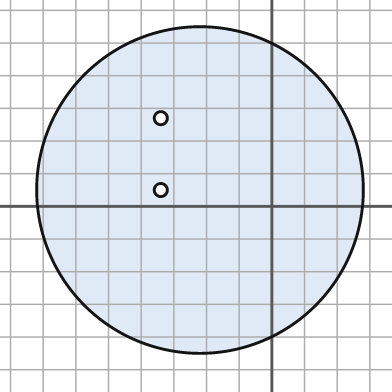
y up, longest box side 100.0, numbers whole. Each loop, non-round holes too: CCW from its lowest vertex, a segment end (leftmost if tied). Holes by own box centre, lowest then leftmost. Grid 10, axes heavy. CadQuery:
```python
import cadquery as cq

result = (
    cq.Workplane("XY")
    .moveTo(-22.0, 5.0)
    .circle(50.0)
    .moveTo(-34.0, 5.0)
    .circle(2.0)
    .moveTo(-34.0, 27.0)
    .circle(2.0)
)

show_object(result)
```